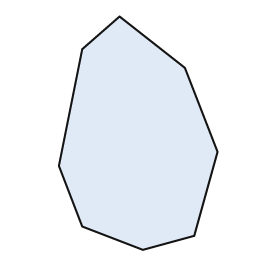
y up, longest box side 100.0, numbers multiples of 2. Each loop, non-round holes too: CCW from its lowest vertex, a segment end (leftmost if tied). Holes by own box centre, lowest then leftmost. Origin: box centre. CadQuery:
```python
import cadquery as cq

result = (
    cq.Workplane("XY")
    .moveTo(2.0, -50.0)
    .lineTo(24.0, -44.0)
    .lineTo(34.0, -8.0)
    .lineTo(20.0, 28.0)
    .lineTo(-8.0, 50.0)
    .lineTo(-24.0, 36.0)
    .lineTo(-34.0, -14.0)
    .lineTo(-24.0, -40.0)
    .close()
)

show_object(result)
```